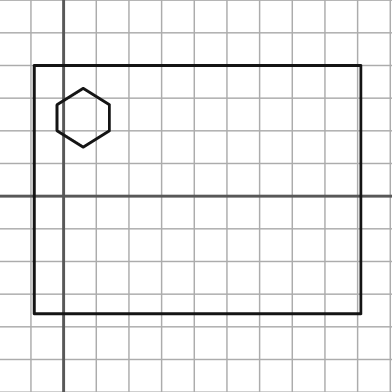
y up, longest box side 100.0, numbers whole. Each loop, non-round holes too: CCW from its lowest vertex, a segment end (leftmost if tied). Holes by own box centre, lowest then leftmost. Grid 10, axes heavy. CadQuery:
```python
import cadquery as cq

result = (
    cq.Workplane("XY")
    .moveTo(-9.0, -36.0)
    .lineTo(91.0, -36.0)
    .lineTo(91.0, 40.0)
    .lineTo(-9.0, 40.0)
    .close()
    .moveTo(6.0, 15.0)
    .lineTo(14.0, 20.0)
    .lineTo(14.0, 28.0)
    .lineTo(6.0, 33.0)
    .lineTo(-2.0, 28.0)
    .lineTo(-2.0, 20.0)
    .close()
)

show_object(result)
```